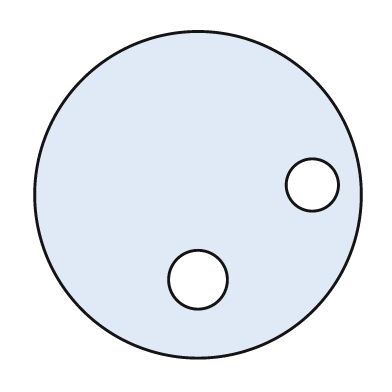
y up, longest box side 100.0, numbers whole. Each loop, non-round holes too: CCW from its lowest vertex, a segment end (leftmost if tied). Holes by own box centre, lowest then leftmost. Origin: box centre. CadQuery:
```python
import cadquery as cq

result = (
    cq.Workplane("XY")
    .moveTo(0.0, 0.0)
    .circle(50.0)
    .moveTo(0.0, -26.0)
    .circle(9.0)
    .moveTo(35.0, 3.0)
    .circle(8.0)
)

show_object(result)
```